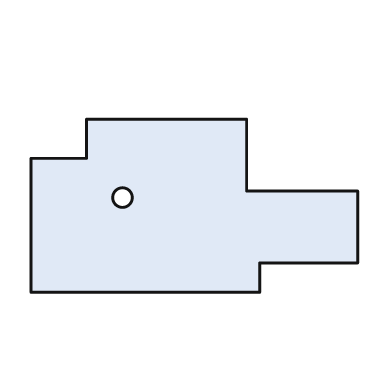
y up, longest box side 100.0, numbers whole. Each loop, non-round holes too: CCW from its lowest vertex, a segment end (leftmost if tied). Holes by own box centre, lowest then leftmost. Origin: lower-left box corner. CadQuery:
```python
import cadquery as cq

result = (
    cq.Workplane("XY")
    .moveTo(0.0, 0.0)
    .lineTo(70.0, 0.0)
    .lineTo(70.0, 9.0)
    .lineTo(100.0, 9.0)
    .lineTo(100.0, 31.0)
    .lineTo(66.0, 31.0)
    .lineTo(66.0, 53.0)
    .lineTo(17.0, 53.0)
    .lineTo(17.0, 41.0)
    .lineTo(0.0, 41.0)
    .close()
    .moveTo(28.0, 29.0)
    .circle(3.0)
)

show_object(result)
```